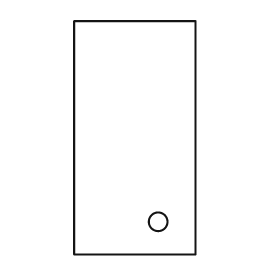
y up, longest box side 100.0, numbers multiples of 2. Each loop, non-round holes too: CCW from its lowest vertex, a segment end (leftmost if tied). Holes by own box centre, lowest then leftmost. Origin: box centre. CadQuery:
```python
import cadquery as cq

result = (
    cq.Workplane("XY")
    .moveTo(-26.0, -50.0)
    .lineTo(26.0, -50.0)
    .lineTo(26.0, 50.0)
    .lineTo(-26.0, 50.0)
    .close()
    .moveTo(10.0, -36.0)
    .circle(4.0)
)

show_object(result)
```